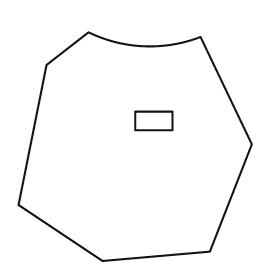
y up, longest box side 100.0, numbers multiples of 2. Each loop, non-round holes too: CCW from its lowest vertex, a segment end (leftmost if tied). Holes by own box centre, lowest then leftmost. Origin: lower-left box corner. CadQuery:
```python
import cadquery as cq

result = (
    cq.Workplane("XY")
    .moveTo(36.0, 0.0)
    .lineTo(82.0, 4.0)
    .lineTo(100.0, 50.0)
    .lineTo(78.0, 96.0)
    .threePointArc((54.0, 92.0), (30.0, 98.0))
    .lineTo(12.0, 84.0)
    .lineTo(0.0, 24.0)
    .close()
    .moveTo(50.0, 56.0)
    .lineTo(66.0, 56.0)
    .lineTo(66.0, 64.0)
    .lineTo(50.0, 64.0)
    .close()
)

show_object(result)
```